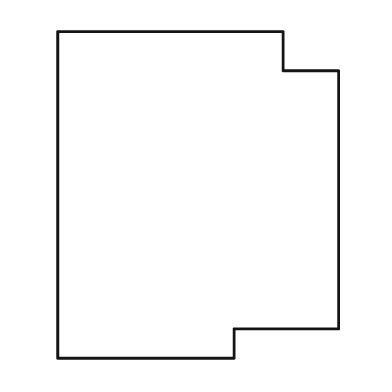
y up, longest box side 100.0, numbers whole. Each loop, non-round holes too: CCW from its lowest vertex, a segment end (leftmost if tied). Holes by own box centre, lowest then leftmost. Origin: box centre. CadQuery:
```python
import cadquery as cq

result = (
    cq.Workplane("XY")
    .moveTo(-43.0, -50.0)
    .lineTo(11.0, -50.0)
    .lineTo(11.0, -41.0)
    .lineTo(43.0, -41.0)
    .lineTo(43.0, 38.0)
    .lineTo(26.0, 38.0)
    .lineTo(26.0, 50.0)
    .lineTo(-43.0, 50.0)
    .close()
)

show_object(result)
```